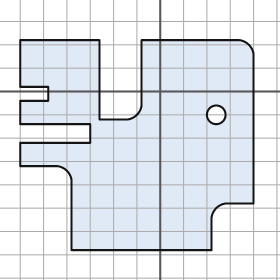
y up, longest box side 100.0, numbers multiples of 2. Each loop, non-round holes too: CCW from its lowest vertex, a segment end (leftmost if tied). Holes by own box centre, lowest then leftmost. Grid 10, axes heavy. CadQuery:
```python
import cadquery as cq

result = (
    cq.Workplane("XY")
    .moveTo(-38.0, -68.0)
    .lineTo(22.0, -68.0)
    .lineTo(22.0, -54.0)
    .threePointArc((24.0, -50.0), (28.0, -48.0))
    .lineTo(40.0, -48.0)
    .lineTo(40.0, 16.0)
    .threePointArc((38.0, 20.0), (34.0, 22.0))
    .lineTo(-8.0, 22.0)
    .lineTo(-8.0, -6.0)
    .threePointArc((-10.0, -10.0), (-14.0, -12.0))
    .lineTo(-26.0, -12.0)
    .lineTo(-26.0, 22.0)
    .lineTo(-60.0, 22.0)
    .lineTo(-60.0, 2.0)
    .lineTo(-48.0, 2.0)
    .lineTo(-48.0, -4.0)
    .lineTo(-60.0, -4.0)
    .lineTo(-60.0, -14.0)
    .lineTo(-30.0, -14.0)
    .lineTo(-30.0, -22.0)
    .lineTo(-60.0, -22.0)
    .lineTo(-60.0, -32.0)
    .lineTo(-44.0, -32.0)
    .threePointArc((-40.0, -34.0), (-38.0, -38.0))
    .close()
    .moveTo(24.0, -10.0)
    .circle(4.0)
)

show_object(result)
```